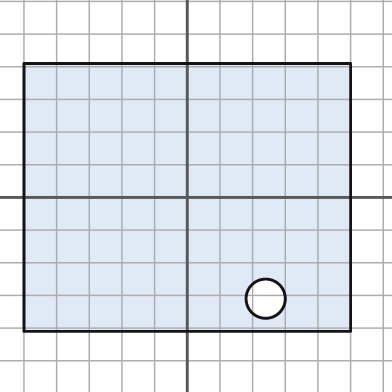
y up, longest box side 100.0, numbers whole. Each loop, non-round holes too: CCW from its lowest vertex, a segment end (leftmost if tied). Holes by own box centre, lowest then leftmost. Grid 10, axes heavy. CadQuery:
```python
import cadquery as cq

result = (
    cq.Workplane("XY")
    .moveTo(-50.0, -41.0)
    .lineTo(50.0, -41.0)
    .lineTo(50.0, 41.0)
    .lineTo(-50.0, 41.0)
    .close()
    .moveTo(24.0, -31.0)
    .circle(6.0)
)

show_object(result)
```